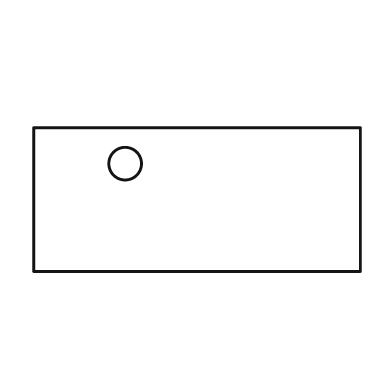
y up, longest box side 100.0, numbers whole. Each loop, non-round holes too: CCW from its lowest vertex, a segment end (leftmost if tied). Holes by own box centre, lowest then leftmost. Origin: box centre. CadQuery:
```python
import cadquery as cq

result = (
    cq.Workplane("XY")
    .moveTo(-50.0, -22.0)
    .lineTo(50.0, -22.0)
    .lineTo(50.0, 22.0)
    .lineTo(-50.0, 22.0)
    .close()
    .moveTo(-22.0, 11.0)
    .circle(5.0)
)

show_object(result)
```